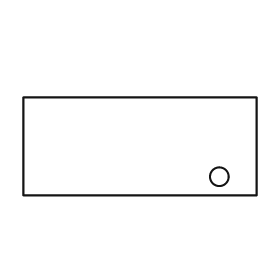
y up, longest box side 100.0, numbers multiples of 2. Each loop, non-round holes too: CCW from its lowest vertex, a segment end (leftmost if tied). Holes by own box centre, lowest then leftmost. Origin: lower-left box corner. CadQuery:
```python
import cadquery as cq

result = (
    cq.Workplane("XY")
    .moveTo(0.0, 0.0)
    .lineTo(100.0, 0.0)
    .lineTo(100.0, 42.0)
    .lineTo(0.0, 42.0)
    .close()
    .moveTo(84.0, 8.0)
    .circle(4.0)
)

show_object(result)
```